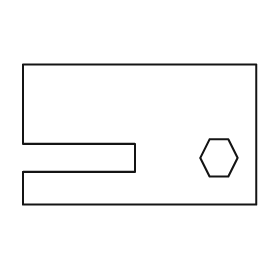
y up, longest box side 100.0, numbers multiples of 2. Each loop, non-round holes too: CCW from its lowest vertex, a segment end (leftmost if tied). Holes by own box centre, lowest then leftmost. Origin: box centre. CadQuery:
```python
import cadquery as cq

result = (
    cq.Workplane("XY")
    .moveTo(-50.0, -30.0)
    .lineTo(50.0, -30.0)
    .lineTo(50.0, 30.0)
    .lineTo(-50.0, 30.0)
    .lineTo(-50.0, -4.0)
    .lineTo(-2.0, -4.0)
    .lineTo(-2.0, -16.0)
    .lineTo(-50.0, -16.0)
    .close()
    .moveTo(30.0, -18.0)
    .lineTo(38.0, -18.0)
    .lineTo(42.0, -10.0)
    .lineTo(38.0, -2.0)
    .lineTo(30.0, -2.0)
    .lineTo(26.0, -10.0)
    .close()
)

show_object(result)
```